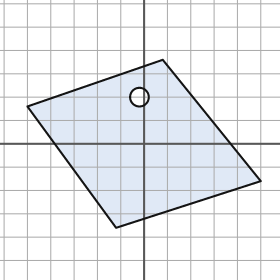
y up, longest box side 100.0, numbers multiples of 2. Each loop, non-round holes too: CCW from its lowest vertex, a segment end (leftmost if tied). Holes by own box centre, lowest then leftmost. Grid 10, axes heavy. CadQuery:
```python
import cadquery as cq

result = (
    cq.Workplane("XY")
    .moveTo(-12.0, -36.0)
    .lineTo(50.0, -16.0)
    .lineTo(8.0, 36.0)
    .lineTo(-50.0, 16.0)
    .close()
    .moveTo(-2.0, 20.0)
    .circle(4.0)
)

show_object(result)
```